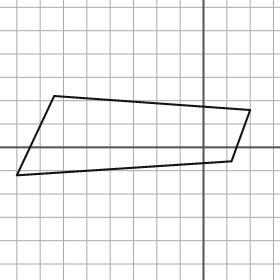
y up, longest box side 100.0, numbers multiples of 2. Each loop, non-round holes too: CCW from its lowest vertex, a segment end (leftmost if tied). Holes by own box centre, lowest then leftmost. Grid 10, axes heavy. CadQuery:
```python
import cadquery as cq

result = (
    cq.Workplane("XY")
    .moveTo(-80.0, -12.0)
    .lineTo(12.0, -6.0)
    .lineTo(20.0, 16.0)
    .lineTo(-64.0, 22.0)
    .close()
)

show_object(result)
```